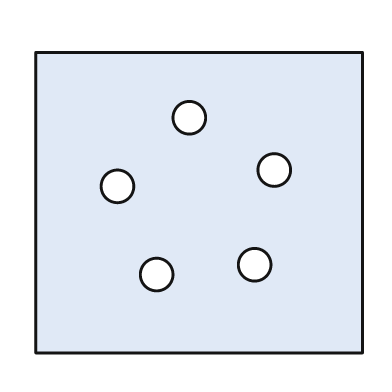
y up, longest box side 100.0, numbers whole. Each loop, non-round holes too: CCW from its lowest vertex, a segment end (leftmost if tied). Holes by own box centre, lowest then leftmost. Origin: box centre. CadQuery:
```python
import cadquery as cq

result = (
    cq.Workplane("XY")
    .moveTo(-50.0, -46.0)
    .lineTo(50.0, -46.0)
    .lineTo(50.0, 46.0)
    .lineTo(-50.0, 46.0)
    .close()
    .moveTo(-13.0, -22.0)
    .circle(5.0)
    .moveTo(17.0, -19.0)
    .circle(5.0)
    .moveTo(-25.0, 5.0)
    .circle(5.0)
    .moveTo(23.0, 10.0)
    .circle(5.0)
    .moveTo(-3.0, 26.0)
    .circle(5.0)
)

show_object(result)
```